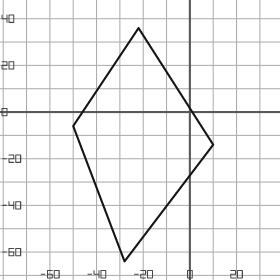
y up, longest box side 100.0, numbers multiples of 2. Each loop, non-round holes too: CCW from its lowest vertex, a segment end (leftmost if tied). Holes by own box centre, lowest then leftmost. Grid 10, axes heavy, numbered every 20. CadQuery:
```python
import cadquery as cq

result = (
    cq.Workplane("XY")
    .moveTo(-28.0, -64.0)
    .lineTo(10.0, -14.0)
    .lineTo(-22.0, 36.0)
    .lineTo(-50.0, -6.0)
    .close()
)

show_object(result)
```